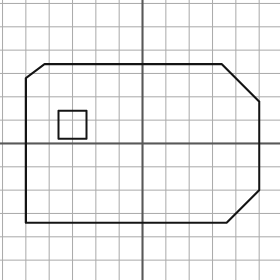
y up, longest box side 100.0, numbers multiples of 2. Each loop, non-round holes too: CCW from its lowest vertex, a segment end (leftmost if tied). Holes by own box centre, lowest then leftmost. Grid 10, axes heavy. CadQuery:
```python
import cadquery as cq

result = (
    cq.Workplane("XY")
    .moveTo(-50.0, -34.0)
    .lineTo(36.0, -34.0)
    .lineTo(50.0, -20.0)
    .lineTo(50.0, 18.0)
    .lineTo(34.0, 34.0)
    .lineTo(-42.0, 34.0)
    .lineTo(-50.0, 28.0)
    .close()
    .moveTo(-36.0, 2.0)
    .lineTo(-24.0, 2.0)
    .lineTo(-24.0, 14.0)
    .lineTo(-36.0, 14.0)
    .close()
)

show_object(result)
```